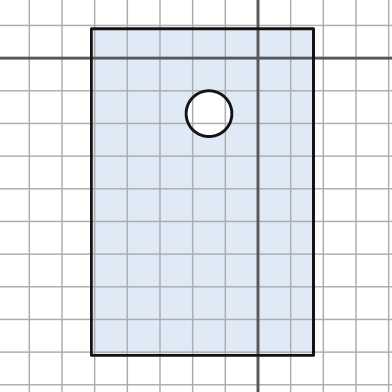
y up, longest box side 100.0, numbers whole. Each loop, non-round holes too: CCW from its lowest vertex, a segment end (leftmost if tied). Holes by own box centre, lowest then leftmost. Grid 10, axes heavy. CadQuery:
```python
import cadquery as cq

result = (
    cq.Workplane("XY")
    .moveTo(-51.0, -91.0)
    .lineTo(17.0, -91.0)
    .lineTo(17.0, 9.0)
    .lineTo(-51.0, 9.0)
    .close()
    .moveTo(-15.0, -17.0)
    .circle(7.0)
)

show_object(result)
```